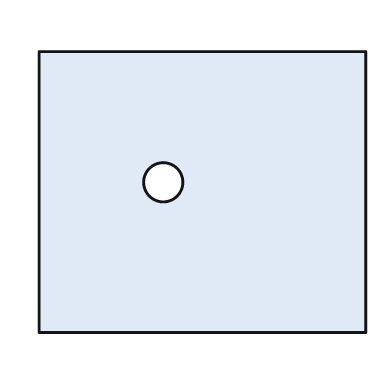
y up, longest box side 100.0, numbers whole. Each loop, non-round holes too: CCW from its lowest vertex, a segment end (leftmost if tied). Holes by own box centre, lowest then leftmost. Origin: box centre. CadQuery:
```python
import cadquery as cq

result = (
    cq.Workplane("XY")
    .moveTo(-50.0, -43.0)
    .lineTo(50.0, -43.0)
    .lineTo(50.0, 43.0)
    .lineTo(-50.0, 43.0)
    .close()
    .moveTo(-12.0, 3.0)
    .circle(6.0)
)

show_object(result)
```